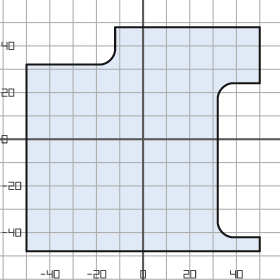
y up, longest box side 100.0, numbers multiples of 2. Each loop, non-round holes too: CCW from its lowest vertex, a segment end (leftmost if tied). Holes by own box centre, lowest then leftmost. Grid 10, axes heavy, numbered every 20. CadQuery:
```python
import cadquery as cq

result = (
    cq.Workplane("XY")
    .moveTo(-50.0, -48.0)
    .lineTo(50.0, -48.0)
    .lineTo(50.0, -42.0)
    .lineTo(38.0, -42.0)
    .threePointArc((34.0, -40.0), (32.0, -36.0))
    .lineTo(32.0, 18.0)
    .threePointArc((34.0, 22.0), (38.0, 24.0))
    .lineTo(50.0, 24.0)
    .lineTo(50.0, 48.0)
    .lineTo(-12.0, 48.0)
    .lineTo(-12.0, 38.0)
    .threePointArc((-14.0, 34.0), (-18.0, 32.0))
    .lineTo(-50.0, 32.0)
    .close()
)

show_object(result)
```